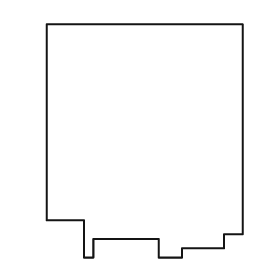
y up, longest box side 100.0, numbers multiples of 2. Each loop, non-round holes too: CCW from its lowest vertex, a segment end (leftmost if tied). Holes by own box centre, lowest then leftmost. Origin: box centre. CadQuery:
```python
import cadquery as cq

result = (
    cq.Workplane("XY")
    .moveTo(-26.0, -50.0)
    .lineTo(-22.0, -50.0)
    .lineTo(-22.0, -42.0)
    .lineTo(6.0, -42.0)
    .lineTo(6.0, -50.0)
    .lineTo(16.0, -50.0)
    .lineTo(16.0, -46.0)
    .lineTo(34.0, -46.0)
    .lineTo(34.0, -40.0)
    .lineTo(42.0, -40.0)
    .lineTo(42.0, 50.0)
    .lineTo(-42.0, 50.0)
    .lineTo(-42.0, -34.0)
    .lineTo(-26.0, -34.0)
    .close()
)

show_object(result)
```